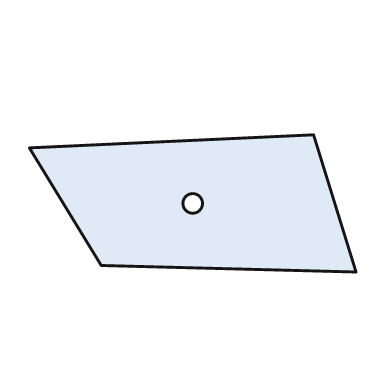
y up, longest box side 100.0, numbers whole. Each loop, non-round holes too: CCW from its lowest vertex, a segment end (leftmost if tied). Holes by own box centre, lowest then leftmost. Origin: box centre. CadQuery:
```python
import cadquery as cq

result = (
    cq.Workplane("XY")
    .moveTo(50.0, -21.0)
    .lineTo(37.0, 21.0)
    .lineTo(-50.0, 17.0)
    .lineTo(-28.0, -19.0)
    .close()
    .moveTo(0.0, 0.0)
    .circle(3.0)
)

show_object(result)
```